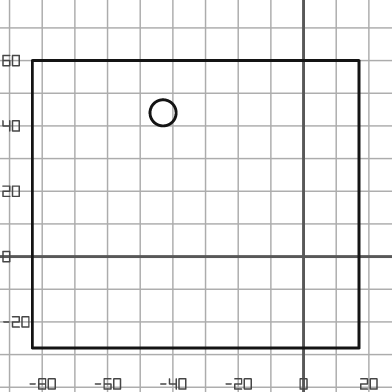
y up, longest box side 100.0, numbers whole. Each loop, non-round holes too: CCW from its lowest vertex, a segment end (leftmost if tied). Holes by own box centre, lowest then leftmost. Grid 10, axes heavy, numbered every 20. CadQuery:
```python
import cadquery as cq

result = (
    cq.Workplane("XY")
    .moveTo(-83.0, -28.0)
    .lineTo(17.0, -28.0)
    .lineTo(17.0, 60.0)
    .lineTo(-83.0, 60.0)
    .close()
    .moveTo(-43.0, 44.0)
    .circle(4.0)
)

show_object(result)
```